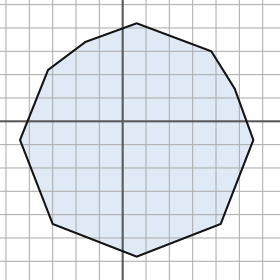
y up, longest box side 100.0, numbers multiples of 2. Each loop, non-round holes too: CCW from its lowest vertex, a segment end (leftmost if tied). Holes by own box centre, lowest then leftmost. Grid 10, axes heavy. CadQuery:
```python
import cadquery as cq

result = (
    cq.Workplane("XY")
    .moveTo(6.0, -58.0)
    .lineTo(42.0, -44.0)
    .lineTo(56.0, -8.0)
    .lineTo(48.0, 14.0)
    .lineTo(38.0, 30.0)
    .lineTo(6.0, 42.0)
    .lineTo(-16.0, 34.0)
    .lineTo(-32.0, 22.0)
    .lineTo(-44.0, -8.0)
    .lineTo(-30.0, -44.0)
    .close()
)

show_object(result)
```